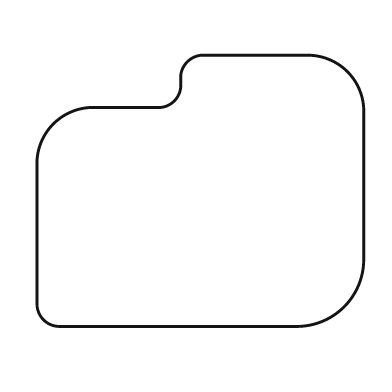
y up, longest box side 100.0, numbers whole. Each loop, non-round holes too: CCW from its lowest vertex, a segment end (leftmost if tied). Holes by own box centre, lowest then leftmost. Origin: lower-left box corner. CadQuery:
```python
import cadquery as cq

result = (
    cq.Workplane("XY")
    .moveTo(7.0, 0.0)
    .lineTo(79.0, 0.0)
    .threePointArc((94.0, 6.0), (100.0, 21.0))
    .lineTo(100.0, 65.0)
    .threePointArc((95.0, 78.0), (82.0, 83.0))
    .lineTo(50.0, 83.0)
    .threePointArc((46.0, 81.0), (44.0, 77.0))
    .lineTo(44.0, 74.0)
    .threePointArc((42.0, 69.0), (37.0, 67.0))
    .lineTo(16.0, 67.0)
    .threePointArc((5.0, 62.0), (0.0, 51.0))
    .lineTo(0.0, 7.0)
    .threePointArc((2.0, 2.0), (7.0, 0.0))
    .close()
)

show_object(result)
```